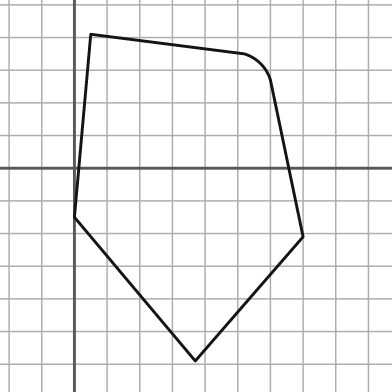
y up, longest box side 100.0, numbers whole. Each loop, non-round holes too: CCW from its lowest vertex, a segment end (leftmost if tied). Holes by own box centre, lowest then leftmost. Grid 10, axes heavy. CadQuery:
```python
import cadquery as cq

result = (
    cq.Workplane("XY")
    .moveTo(37.0, -59.0)
    .lineTo(70.0, -21.0)
    .lineTo(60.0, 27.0)
    .threePointArc((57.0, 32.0), (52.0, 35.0))
    .lineTo(5.0, 41.0)
    .lineTo(0.0, -15.0)
    .close()
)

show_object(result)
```